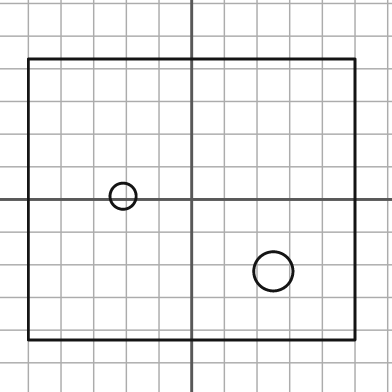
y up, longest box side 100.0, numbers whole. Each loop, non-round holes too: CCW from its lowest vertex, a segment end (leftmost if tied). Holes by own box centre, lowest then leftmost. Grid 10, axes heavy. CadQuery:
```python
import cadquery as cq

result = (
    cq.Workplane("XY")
    .moveTo(-50.0, -43.0)
    .lineTo(50.0, -43.0)
    .lineTo(50.0, 43.0)
    .lineTo(-50.0, 43.0)
    .close()
    .moveTo(25.0, -22.0)
    .circle(6.0)
    .moveTo(-21.0, 1.0)
    .circle(4.0)
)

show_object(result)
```